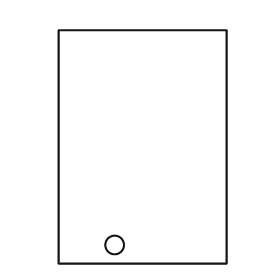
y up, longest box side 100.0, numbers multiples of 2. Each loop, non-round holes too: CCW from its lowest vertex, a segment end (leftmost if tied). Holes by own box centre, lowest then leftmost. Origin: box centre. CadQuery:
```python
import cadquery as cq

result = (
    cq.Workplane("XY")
    .moveTo(-36.0, -50.0)
    .lineTo(36.0, -50.0)
    .lineTo(36.0, 50.0)
    .lineTo(-36.0, 50.0)
    .close()
    .moveTo(-12.0, -42.0)
    .circle(4.0)
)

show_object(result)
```